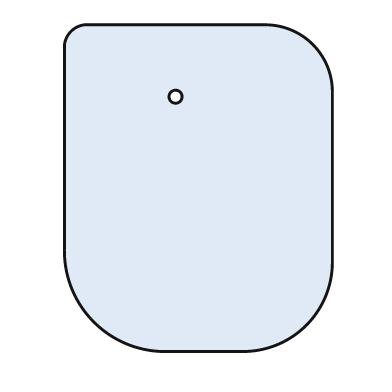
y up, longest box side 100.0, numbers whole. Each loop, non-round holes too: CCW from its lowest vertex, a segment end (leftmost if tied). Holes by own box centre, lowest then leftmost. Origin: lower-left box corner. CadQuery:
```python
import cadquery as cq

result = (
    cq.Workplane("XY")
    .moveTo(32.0, 0.0)
    .lineTo(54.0, 0.0)
    .threePointArc((74.0, 8.0), (82.0, 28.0))
    .lineTo(82.0, 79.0)
    .threePointArc((76.0, 94.0), (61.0, 100.0))
    .lineTo(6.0, 100.0)
    .threePointArc((2.0, 98.0), (0.0, 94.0))
    .lineTo(0.0, 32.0)
    .threePointArc((9.0, 9.0), (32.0, 0.0))
    .close()
    .moveTo(34.0, 78.0)
    .circle(2.0)
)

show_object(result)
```